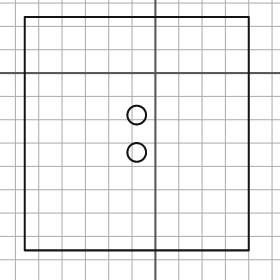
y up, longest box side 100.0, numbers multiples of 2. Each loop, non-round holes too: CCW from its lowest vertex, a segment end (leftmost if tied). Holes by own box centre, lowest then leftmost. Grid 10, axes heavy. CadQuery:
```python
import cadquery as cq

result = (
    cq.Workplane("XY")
    .moveTo(-56.0, -76.0)
    .lineTo(40.0, -76.0)
    .lineTo(40.0, 24.0)
    .lineTo(-56.0, 24.0)
    .close()
    .moveTo(-8.0, -34.0)
    .circle(4.0)
    .moveTo(-8.0, -18.0)
    .circle(4.0)
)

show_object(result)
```